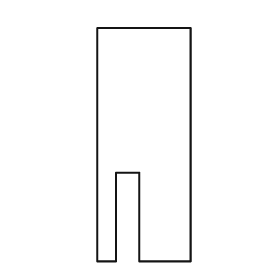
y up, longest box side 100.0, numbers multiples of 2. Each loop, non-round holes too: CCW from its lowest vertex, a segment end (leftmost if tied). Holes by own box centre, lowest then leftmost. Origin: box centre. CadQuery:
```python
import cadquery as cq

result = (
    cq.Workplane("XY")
    .moveTo(-20.0, -50.0)
    .lineTo(-12.0, -50.0)
    .lineTo(-12.0, -12.0)
    .lineTo(-2.0, -12.0)
    .lineTo(-2.0, -50.0)
    .lineTo(20.0, -50.0)
    .lineTo(20.0, 50.0)
    .lineTo(-20.0, 50.0)
    .close()
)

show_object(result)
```